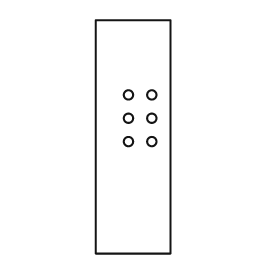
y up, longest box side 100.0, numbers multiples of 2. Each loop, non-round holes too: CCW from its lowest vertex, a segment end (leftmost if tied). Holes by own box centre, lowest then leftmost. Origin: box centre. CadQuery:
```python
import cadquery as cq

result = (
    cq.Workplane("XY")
    .moveTo(-16.0, -50.0)
    .lineTo(16.0, -50.0)
    .lineTo(16.0, 50.0)
    .lineTo(-16.0, 50.0)
    .close()
    .moveTo(-2.0, -2.0)
    .circle(2.0)
    .moveTo(8.0, -2.0)
    .circle(2.0)
    .moveTo(-2.0, 8.0)
    .circle(2.0)
    .moveTo(8.0, 8.0)
    .circle(2.0)
    .moveTo(-2.0, 18.0)
    .circle(2.0)
    .moveTo(8.0, 18.0)
    .circle(2.0)
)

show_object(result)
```